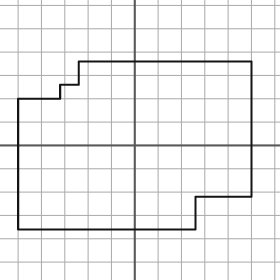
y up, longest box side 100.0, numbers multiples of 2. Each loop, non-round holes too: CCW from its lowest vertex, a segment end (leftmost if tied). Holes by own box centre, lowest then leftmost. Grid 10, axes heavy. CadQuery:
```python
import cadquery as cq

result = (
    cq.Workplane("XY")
    .moveTo(-50.0, -36.0)
    .lineTo(26.0, -36.0)
    .lineTo(26.0, -22.0)
    .lineTo(50.0, -22.0)
    .lineTo(50.0, 36.0)
    .lineTo(-24.0, 36.0)
    .lineTo(-24.0, 26.0)
    .lineTo(-32.0, 26.0)
    .lineTo(-32.0, 20.0)
    .lineTo(-50.0, 20.0)
    .close()
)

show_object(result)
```